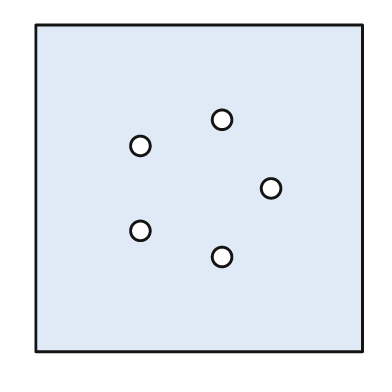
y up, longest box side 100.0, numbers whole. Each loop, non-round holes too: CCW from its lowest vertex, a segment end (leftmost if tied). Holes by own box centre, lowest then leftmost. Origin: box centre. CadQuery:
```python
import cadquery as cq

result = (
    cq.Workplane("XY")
    .moveTo(-50.0, -50.0)
    .lineTo(50.0, -50.0)
    .lineTo(50.0, 50.0)
    .lineTo(-50.0, 50.0)
    .close()
    .moveTo(7.0, -21.0)
    .circle(3.0)
    .moveTo(-18.0, -13.0)
    .circle(3.0)
    .moveTo(22.0, 0.0)
    .circle(3.0)
    .moveTo(-18.0, 13.0)
    .circle(3.0)
    .moveTo(7.0, 21.0)
    .circle(3.0)
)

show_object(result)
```